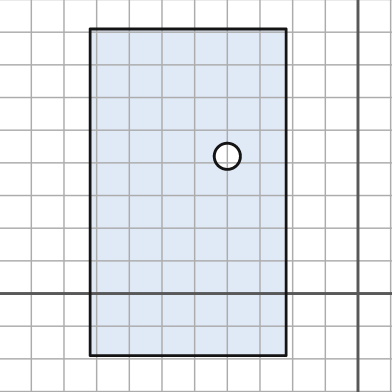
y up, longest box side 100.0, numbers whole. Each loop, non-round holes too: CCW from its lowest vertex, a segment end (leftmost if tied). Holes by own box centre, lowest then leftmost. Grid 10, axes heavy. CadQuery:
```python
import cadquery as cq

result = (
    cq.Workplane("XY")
    .moveTo(-82.0, -19.0)
    .lineTo(-22.0, -19.0)
    .lineTo(-22.0, 81.0)
    .lineTo(-82.0, 81.0)
    .close()
    .moveTo(-40.0, 42.0)
    .circle(4.0)
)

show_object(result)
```